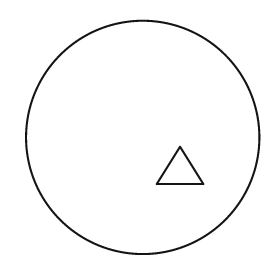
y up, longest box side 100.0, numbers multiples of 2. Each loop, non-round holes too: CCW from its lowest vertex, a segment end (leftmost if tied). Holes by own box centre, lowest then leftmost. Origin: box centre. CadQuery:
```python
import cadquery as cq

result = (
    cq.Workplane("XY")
    .moveTo(0.0, 0.0)
    .circle(50.0)
    .moveTo(6.0, -20.0)
    .lineTo(26.0, -20.0)
    .lineTo(16.0, -4.0)
    .close()
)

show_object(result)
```